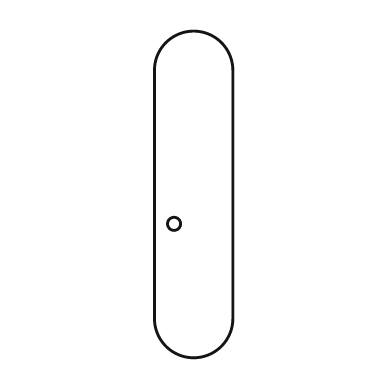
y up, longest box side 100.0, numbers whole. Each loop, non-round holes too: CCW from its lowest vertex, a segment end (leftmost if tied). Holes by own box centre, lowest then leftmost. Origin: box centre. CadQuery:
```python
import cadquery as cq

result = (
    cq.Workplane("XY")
    .moveTo(-12.0, -38.0)
    .threePointArc((0.0, -50.0), (12.0, -38.0))
    .lineTo(12.0, 38.0)
    .threePointArc((0.0, 50.0), (-12.0, 38.0))
    .close()
    .moveTo(-6.0, -9.0)
    .circle(2.0)
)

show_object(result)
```